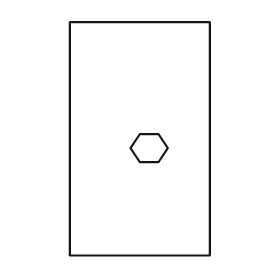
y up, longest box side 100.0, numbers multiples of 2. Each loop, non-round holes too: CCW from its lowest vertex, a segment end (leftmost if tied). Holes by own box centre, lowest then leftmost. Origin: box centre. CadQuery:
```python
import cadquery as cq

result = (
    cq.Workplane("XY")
    .moveTo(-30.0, -50.0)
    .lineTo(30.0, -50.0)
    .lineTo(30.0, 50.0)
    .lineTo(-30.0, 50.0)
    .close()
    .moveTo(0.0, -10.0)
    .lineTo(8.0, -10.0)
    .lineTo(12.0, -4.0)
    .lineTo(8.0, 2.0)
    .lineTo(0.0, 2.0)
    .lineTo(-4.0, -4.0)
    .close()
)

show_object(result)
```